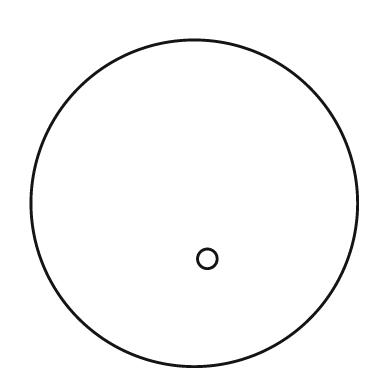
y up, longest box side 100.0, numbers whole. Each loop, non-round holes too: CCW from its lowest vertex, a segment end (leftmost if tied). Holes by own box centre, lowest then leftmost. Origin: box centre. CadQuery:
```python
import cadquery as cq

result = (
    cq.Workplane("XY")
    .moveTo(0.0, 0.0)
    .circle(50.0)
    .moveTo(4.0, -17.0)
    .circle(3.0)
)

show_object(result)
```